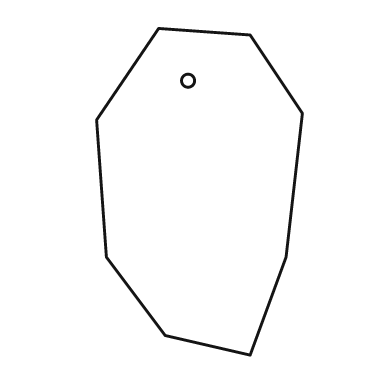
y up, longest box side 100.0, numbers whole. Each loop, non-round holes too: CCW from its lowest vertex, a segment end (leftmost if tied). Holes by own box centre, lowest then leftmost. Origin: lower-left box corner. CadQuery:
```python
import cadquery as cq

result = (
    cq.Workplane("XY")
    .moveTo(47.0, 0.0)
    .lineTo(58.0, 30.0)
    .lineTo(63.0, 74.0)
    .lineTo(47.0, 98.0)
    .lineTo(19.0, 100.0)
    .lineTo(0.0, 72.0)
    .lineTo(3.0, 30.0)
    .lineTo(21.0, 6.0)
    .close()
    .moveTo(28.0, 84.0)
    .circle(2.0)
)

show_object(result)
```